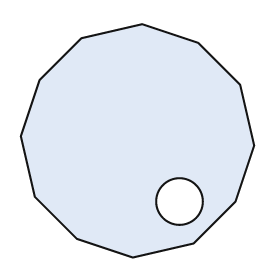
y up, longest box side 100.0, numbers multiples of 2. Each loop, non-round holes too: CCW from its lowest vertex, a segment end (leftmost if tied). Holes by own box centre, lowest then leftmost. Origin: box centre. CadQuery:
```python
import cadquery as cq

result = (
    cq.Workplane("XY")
    .moveTo(-2.0, -50.0)
    .lineTo(24.0, -44.0)
    .lineTo(42.0, -26.0)
    .lineTo(50.0, -2.0)
    .lineTo(44.0, 24.0)
    .lineTo(26.0, 42.0)
    .lineTo(2.0, 50.0)
    .lineTo(-24.0, 44.0)
    .lineTo(-42.0, 26.0)
    .lineTo(-50.0, 2.0)
    .lineTo(-44.0, -24.0)
    .lineTo(-26.0, -42.0)
    .close()
    .moveTo(18.0, -26.0)
    .circle(10.0)
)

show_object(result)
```